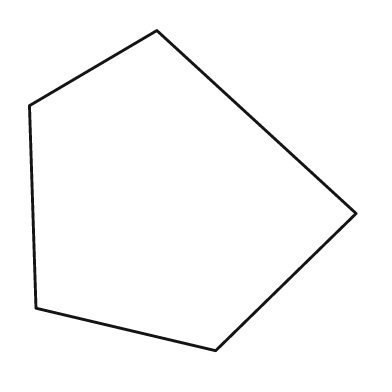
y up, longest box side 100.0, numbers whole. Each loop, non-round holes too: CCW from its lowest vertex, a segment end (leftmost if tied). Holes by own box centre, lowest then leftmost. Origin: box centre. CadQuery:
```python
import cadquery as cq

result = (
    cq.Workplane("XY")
    .moveTo(7.0, -49.0)
    .lineTo(50.0, -7.0)
    .lineTo(-11.0, 49.0)
    .lineTo(-50.0, 26.0)
    .lineTo(-48.0, -36.0)
    .close()
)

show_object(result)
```